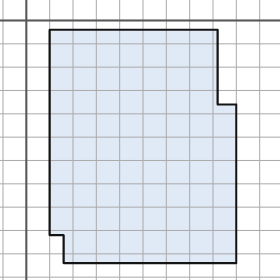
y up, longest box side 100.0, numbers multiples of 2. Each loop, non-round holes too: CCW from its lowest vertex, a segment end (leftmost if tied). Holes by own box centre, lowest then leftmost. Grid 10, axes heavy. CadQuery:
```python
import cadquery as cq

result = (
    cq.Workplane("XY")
    .moveTo(16.0, -104.0)
    .lineTo(90.0, -104.0)
    .lineTo(90.0, -36.0)
    .lineTo(82.0, -36.0)
    .lineTo(82.0, -4.0)
    .lineTo(10.0, -4.0)
    .lineTo(10.0, -92.0)
    .lineTo(16.0, -92.0)
    .close()
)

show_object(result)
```